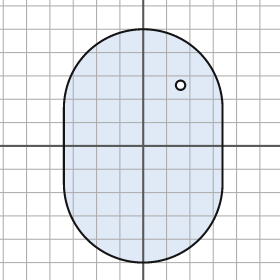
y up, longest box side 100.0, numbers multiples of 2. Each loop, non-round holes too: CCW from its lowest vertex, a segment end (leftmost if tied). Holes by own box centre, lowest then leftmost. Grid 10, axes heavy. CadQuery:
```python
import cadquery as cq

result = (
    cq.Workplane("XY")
    .moveTo(-34.0, -16.0)
    .threePointArc((0.0, -50.0), (34.0, -16.0))
    .lineTo(34.0, 16.0)
    .threePointArc((0.0, 50.0), (-34.0, 16.0))
    .close()
    .moveTo(16.0, 26.0)
    .circle(2.0)
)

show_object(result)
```